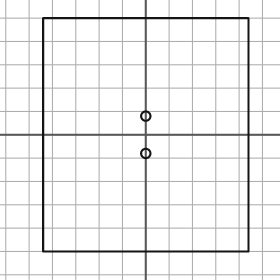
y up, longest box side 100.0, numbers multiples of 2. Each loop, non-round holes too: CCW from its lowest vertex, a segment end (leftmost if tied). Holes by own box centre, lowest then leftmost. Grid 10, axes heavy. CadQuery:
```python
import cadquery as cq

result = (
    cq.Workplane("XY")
    .moveTo(-44.0, -50.0)
    .lineTo(44.0, -50.0)
    .lineTo(44.0, 50.0)
    .lineTo(-44.0, 50.0)
    .close()
    .moveTo(0.0, -8.0)
    .circle(2.0)
    .moveTo(0.0, 8.0)
    .circle(2.0)
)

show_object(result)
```